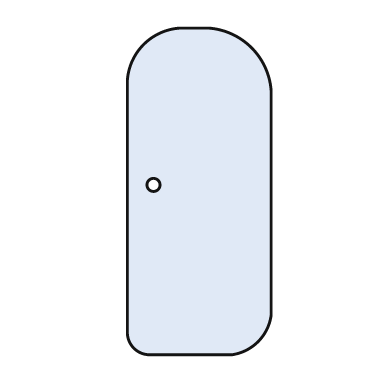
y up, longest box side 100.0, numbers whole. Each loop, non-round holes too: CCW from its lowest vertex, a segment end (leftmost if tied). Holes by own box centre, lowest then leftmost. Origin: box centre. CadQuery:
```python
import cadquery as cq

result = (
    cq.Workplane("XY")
    .moveTo(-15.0, -50.0)
    .lineTo(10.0, -50.0)
    .threePointArc((18.0, -46.0), (22.0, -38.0))
    .lineTo(22.0, 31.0)
    .threePointArc((16.0, 44.0), (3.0, 50.0))
    .lineTo(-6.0, 50.0)
    .threePointArc((-17.0, 45.0), (-22.0, 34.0))
    .lineTo(-22.0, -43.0)
    .threePointArc((-20.0, -48.0), (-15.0, -50.0))
    .close()
    .moveTo(-14.0, 2.0)
    .circle(2.0)
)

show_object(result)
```